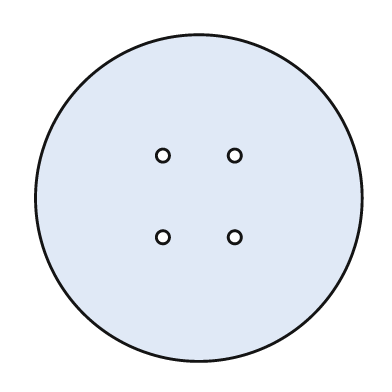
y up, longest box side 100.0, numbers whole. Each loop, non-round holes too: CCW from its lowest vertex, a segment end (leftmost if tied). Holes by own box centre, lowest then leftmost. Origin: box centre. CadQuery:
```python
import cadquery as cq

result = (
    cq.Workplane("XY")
    .moveTo(0.0, 0.0)
    .circle(50.0)
    .moveTo(-11.0, -12.0)
    .circle(2.0)
    .moveTo(11.0, -12.0)
    .circle(2.0)
    .moveTo(-11.0, 13.0)
    .circle(2.0)
    .moveTo(11.0, 13.0)
    .circle(2.0)
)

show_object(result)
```